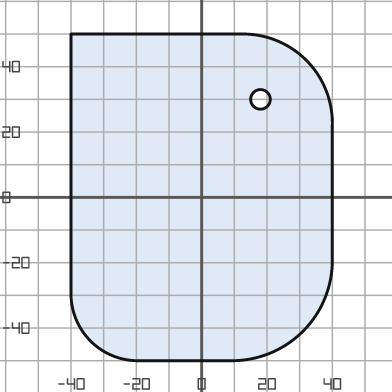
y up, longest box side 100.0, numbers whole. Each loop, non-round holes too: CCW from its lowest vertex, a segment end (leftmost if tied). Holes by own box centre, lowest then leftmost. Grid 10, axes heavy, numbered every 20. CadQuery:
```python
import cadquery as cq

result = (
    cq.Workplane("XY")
    .moveTo(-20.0, -50.0)
    .lineTo(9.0, -50.0)
    .threePointArc((31.0, -41.0), (40.0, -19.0))
    .lineTo(40.0, 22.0)
    .threePointArc((32.0, 42.0), (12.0, 50.0))
    .lineTo(-40.0, 50.0)
    .lineTo(-40.0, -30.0)
    .threePointArc((-34.0, -44.0), (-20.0, -50.0))
    .close()
    .moveTo(18.0, 30.0)
    .circle(3.0)
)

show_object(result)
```